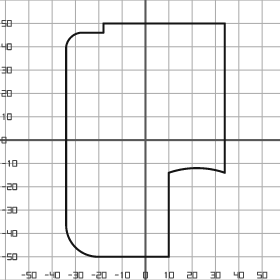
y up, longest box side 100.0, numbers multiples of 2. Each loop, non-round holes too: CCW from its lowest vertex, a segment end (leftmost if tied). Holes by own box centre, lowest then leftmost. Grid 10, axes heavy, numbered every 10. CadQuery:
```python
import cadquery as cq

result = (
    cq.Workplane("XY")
    .moveTo(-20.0, -50.0)
    .lineTo(10.0, -50.0)
    .lineTo(10.0, -14.0)
    .threePointArc((22.0, -12.0), (34.0, -14.0))
    .lineTo(34.0, 50.0)
    .lineTo(-18.0, 50.0)
    .lineTo(-18.0, 46.0)
    .lineTo(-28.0, 46.0)
    .threePointArc((-32.0, 44.0), (-34.0, 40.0))
    .lineTo(-34.0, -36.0)
    .threePointArc((-30.0, -46.0), (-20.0, -50.0))
    .close()
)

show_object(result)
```